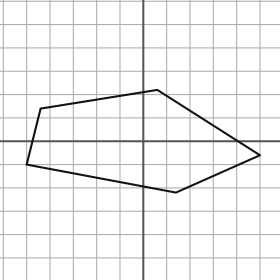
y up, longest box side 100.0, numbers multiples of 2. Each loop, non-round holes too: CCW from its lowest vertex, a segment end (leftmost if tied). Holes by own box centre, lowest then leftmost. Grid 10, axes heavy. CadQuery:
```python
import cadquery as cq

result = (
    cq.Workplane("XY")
    .moveTo(14.0, -22.0)
    .lineTo(50.0, -6.0)
    .lineTo(6.0, 22.0)
    .lineTo(-44.0, 14.0)
    .lineTo(-50.0, -10.0)
    .close()
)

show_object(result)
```